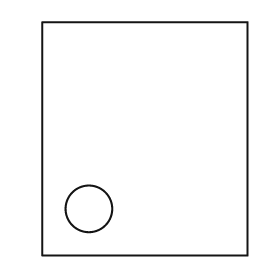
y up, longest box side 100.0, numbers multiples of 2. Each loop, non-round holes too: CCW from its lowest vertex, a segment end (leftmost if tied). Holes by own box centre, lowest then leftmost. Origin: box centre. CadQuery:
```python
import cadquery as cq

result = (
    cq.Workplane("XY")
    .moveTo(-44.0, -50.0)
    .lineTo(44.0, -50.0)
    .lineTo(44.0, 50.0)
    .lineTo(-44.0, 50.0)
    .close()
    .moveTo(-24.0, -30.0)
    .circle(10.0)
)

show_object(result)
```